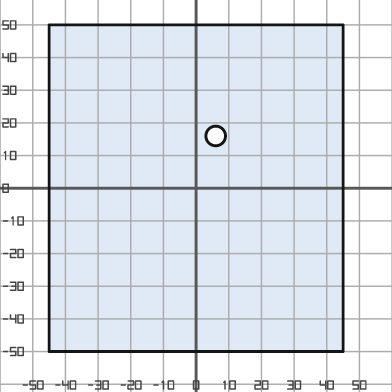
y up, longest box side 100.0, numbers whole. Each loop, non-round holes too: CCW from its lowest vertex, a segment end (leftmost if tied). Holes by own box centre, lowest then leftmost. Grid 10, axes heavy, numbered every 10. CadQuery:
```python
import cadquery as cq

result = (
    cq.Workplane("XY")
    .moveTo(-45.0, -50.0)
    .lineTo(45.0, -50.0)
    .lineTo(45.0, 50.0)
    .lineTo(-45.0, 50.0)
    .close()
    .moveTo(6.0, 16.0)
    .circle(3.0)
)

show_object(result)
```